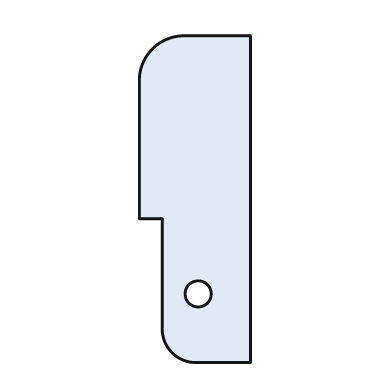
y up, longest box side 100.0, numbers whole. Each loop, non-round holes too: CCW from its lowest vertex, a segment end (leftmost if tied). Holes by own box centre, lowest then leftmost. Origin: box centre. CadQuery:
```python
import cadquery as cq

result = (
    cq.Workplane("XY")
    .moveTo(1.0, -50.0)
    .lineTo(17.0, -50.0)
    .lineTo(17.0, 50.0)
    .lineTo(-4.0, 50.0)
    .threePointArc((-13.0, 46.0), (-17.0, 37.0))
    .lineTo(-17.0, -6.0)
    .lineTo(-10.0, -6.0)
    .lineTo(-10.0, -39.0)
    .threePointArc((-7.0, -47.0), (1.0, -50.0))
    .close()
    .moveTo(1.0, -29.0)
    .circle(4.0)
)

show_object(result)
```